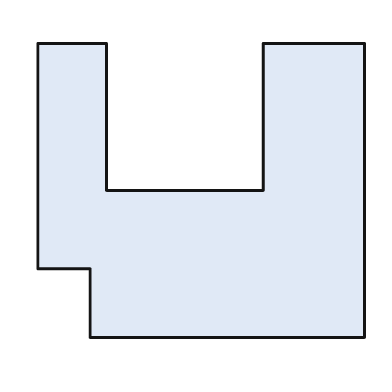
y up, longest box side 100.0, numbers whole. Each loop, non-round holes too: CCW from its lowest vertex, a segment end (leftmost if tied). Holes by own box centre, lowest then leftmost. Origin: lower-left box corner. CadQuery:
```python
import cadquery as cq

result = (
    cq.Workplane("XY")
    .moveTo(16.0, 0.0)
    .lineTo(100.0, 0.0)
    .lineTo(100.0, 90.0)
    .lineTo(69.0, 90.0)
    .lineTo(69.0, 45.0)
    .lineTo(21.0, 45.0)
    .lineTo(21.0, 90.0)
    .lineTo(0.0, 90.0)
    .lineTo(0.0, 21.0)
    .lineTo(16.0, 21.0)
    .close()
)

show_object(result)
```